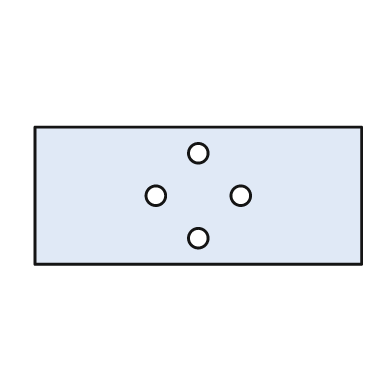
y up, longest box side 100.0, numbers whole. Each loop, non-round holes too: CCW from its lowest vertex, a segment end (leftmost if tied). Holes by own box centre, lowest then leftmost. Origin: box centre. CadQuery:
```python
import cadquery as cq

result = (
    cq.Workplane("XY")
    .moveTo(-50.0, -21.0)
    .lineTo(50.0, -21.0)
    .lineTo(50.0, 21.0)
    .lineTo(-50.0, 21.0)
    .close()
    .moveTo(0.0, -13.0)
    .circle(3.0)
    .moveTo(-13.0, 0.0)
    .circle(3.0)
    .moveTo(13.0, 0.0)
    .circle(3.0)
    .moveTo(0.0, 13.0)
    .circle(3.0)
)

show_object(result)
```